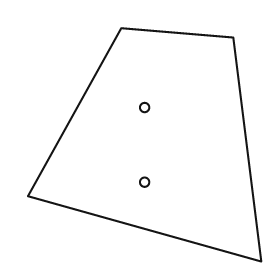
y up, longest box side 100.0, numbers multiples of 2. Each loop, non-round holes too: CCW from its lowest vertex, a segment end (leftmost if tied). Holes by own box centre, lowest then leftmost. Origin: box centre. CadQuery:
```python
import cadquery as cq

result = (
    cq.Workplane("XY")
    .moveTo(50.0, -50.0)
    .lineTo(38.0, 46.0)
    .lineTo(-10.0, 50.0)
    .lineTo(-50.0, -22.0)
    .close()
    .moveTo(0.0, -16.0)
    .circle(2.0)
    .moveTo(0.0, 16.0)
    .circle(2.0)
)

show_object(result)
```